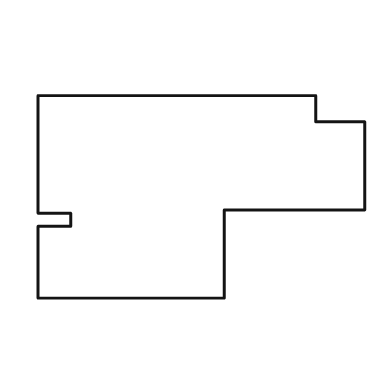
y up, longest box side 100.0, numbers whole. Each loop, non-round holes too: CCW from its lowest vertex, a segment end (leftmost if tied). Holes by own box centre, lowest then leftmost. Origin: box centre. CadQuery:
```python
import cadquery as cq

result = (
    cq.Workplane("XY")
    .moveTo(-50.0, -31.0)
    .lineTo(7.0, -31.0)
    .lineTo(7.0, -4.0)
    .lineTo(50.0, -4.0)
    .lineTo(50.0, 23.0)
    .lineTo(35.0, 23.0)
    .lineTo(35.0, 31.0)
    .lineTo(-50.0, 31.0)
    .lineTo(-50.0, -5.0)
    .lineTo(-40.0, -5.0)
    .lineTo(-40.0, -9.0)
    .lineTo(-50.0, -9.0)
    .close()
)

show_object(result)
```